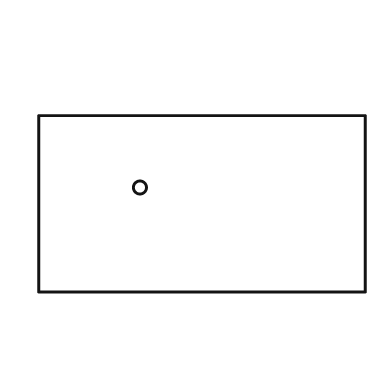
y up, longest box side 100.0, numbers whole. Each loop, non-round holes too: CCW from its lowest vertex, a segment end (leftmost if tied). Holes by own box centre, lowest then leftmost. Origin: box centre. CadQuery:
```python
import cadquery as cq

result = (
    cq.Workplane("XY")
    .moveTo(-50.0, -27.0)
    .lineTo(50.0, -27.0)
    .lineTo(50.0, 27.0)
    .lineTo(-50.0, 27.0)
    .close()
    .moveTo(-19.0, 5.0)
    .circle(2.0)
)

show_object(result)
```